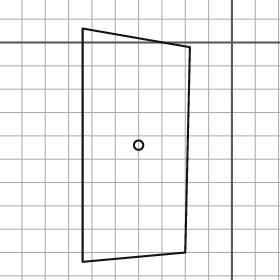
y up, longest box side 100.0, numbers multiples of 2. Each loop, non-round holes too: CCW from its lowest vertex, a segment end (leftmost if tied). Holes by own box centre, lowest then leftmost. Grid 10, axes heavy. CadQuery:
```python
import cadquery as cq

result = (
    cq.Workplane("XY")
    .moveTo(-64.0, -94.0)
    .lineTo(-20.0, -90.0)
    .lineTo(-18.0, -2.0)
    .lineTo(-64.0, 6.0)
    .close()
    .moveTo(-40.0, -44.0)
    .circle(2.0)
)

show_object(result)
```